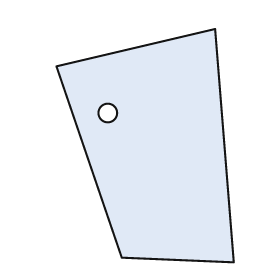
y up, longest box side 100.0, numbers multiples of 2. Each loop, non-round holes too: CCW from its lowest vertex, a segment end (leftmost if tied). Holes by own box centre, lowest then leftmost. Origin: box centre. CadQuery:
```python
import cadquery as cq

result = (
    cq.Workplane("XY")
    .moveTo(38.0, -50.0)
    .lineTo(30.0, 50.0)
    .lineTo(-38.0, 34.0)
    .lineTo(-10.0, -48.0)
    .close()
    .moveTo(-16.0, 14.0)
    .circle(4.0)
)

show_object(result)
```